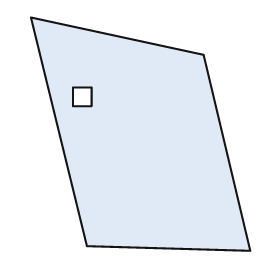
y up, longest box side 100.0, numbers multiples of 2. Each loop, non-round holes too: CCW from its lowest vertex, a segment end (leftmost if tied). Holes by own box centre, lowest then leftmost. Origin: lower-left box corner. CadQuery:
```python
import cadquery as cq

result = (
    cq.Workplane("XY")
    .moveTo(94.0, 0.0)
    .lineTo(74.0, 84.0)
    .lineTo(0.0, 100.0)
    .lineTo(24.0, 2.0)
    .close()
    .moveTo(18.0, 62.0)
    .lineTo(26.0, 62.0)
    .lineTo(26.0, 70.0)
    .lineTo(18.0, 70.0)
    .close()
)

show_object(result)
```